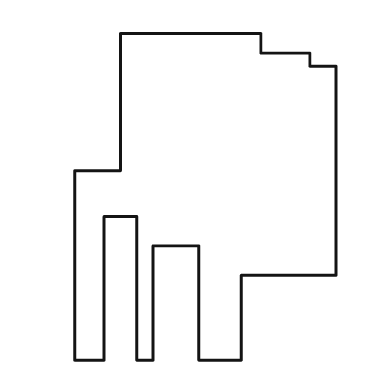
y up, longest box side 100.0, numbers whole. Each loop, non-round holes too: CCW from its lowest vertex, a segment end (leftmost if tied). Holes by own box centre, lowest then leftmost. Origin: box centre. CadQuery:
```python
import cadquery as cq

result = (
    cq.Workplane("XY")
    .moveTo(-40.0, -50.0)
    .lineTo(-31.0, -50.0)
    .lineTo(-31.0, -6.0)
    .lineTo(-21.0, -6.0)
    .lineTo(-21.0, -50.0)
    .lineTo(-16.0, -50.0)
    .lineTo(-16.0, -15.0)
    .lineTo(-2.0, -15.0)
    .lineTo(-2.0, -50.0)
    .lineTo(11.0, -50.0)
    .lineTo(11.0, -24.0)
    .lineTo(40.0, -24.0)
    .lineTo(40.0, 40.0)
    .lineTo(32.0, 40.0)
    .lineTo(32.0, 44.0)
    .lineTo(17.0, 44.0)
    .lineTo(17.0, 50.0)
    .lineTo(-26.0, 50.0)
    .lineTo(-26.0, 8.0)
    .lineTo(-40.0, 8.0)
    .close()
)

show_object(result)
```